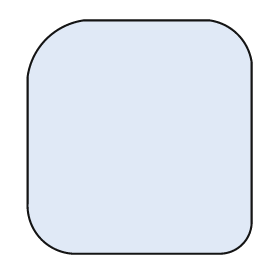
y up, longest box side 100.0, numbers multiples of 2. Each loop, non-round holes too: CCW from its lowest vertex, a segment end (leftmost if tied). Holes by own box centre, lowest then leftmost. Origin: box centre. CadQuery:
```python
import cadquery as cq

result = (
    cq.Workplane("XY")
    .moveTo(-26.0, -50.0)
    .lineTo(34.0, -50.0)
    .threePointArc((44.0, -46.0), (48.0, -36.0))
    .lineTo(48.0, 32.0)
    .threePointArc((42.0, 44.0), (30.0, 50.0))
    .lineTo(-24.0, 50.0)
    .threePointArc((-40.0, 42.0), (-48.0, 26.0))
    .lineTo(-48.0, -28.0)
    .threePointArc((-42.0, -44.0), (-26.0, -50.0))
    .close()
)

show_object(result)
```